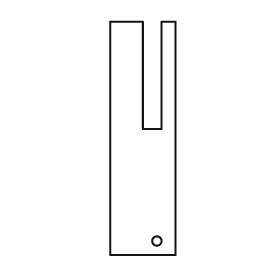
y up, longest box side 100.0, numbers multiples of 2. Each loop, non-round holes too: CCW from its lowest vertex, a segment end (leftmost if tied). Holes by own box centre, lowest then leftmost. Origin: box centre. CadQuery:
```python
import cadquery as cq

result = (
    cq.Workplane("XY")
    .moveTo(-14.0, -50.0)
    .lineTo(14.0, -50.0)
    .lineTo(14.0, 50.0)
    .lineTo(8.0, 50.0)
    .lineTo(8.0, 4.0)
    .lineTo(0.0, 4.0)
    .lineTo(0.0, 50.0)
    .lineTo(-14.0, 50.0)
    .close()
    .moveTo(6.0, -44.0)
    .circle(2.0)
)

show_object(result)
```